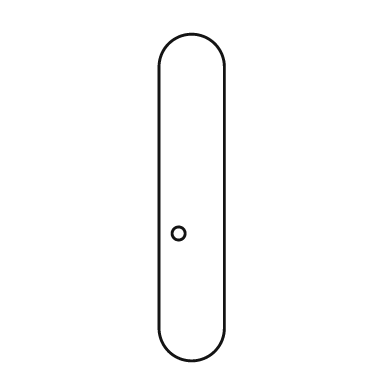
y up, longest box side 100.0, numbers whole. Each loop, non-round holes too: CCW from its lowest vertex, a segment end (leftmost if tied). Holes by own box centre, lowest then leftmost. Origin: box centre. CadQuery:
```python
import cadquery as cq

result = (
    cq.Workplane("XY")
    .moveTo(-10.0, -40.0)
    .threePointArc((0.0, -50.0), (10.0, -40.0))
    .lineTo(10.0, 40.0)
    .threePointArc((0.0, 50.0), (-10.0, 40.0))
    .close()
    .moveTo(-4.0, -11.0)
    .circle(2.0)
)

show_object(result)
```